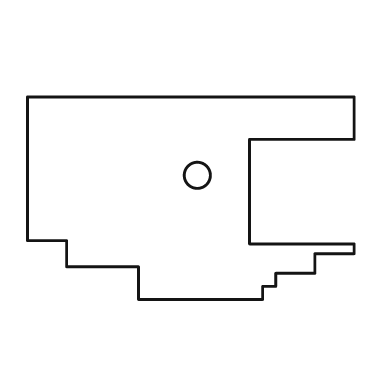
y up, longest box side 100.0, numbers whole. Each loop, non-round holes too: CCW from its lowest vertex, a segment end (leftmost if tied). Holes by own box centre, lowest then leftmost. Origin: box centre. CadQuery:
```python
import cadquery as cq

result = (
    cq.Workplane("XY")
    .moveTo(-16.0, -31.0)
    .lineTo(22.0, -31.0)
    .lineTo(22.0, -27.0)
    .lineTo(26.0, -27.0)
    .lineTo(26.0, -23.0)
    .lineTo(38.0, -23.0)
    .lineTo(38.0, -17.0)
    .lineTo(50.0, -17.0)
    .lineTo(50.0, -14.0)
    .lineTo(18.0, -14.0)
    .lineTo(18.0, 18.0)
    .lineTo(50.0, 18.0)
    .lineTo(50.0, 31.0)
    .lineTo(-50.0, 31.0)
    .lineTo(-50.0, -13.0)
    .lineTo(-38.0, -13.0)
    .lineTo(-38.0, -21.0)
    .lineTo(-16.0, -21.0)
    .close()
    .moveTo(2.0, 7.0)
    .circle(4.0)
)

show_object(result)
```